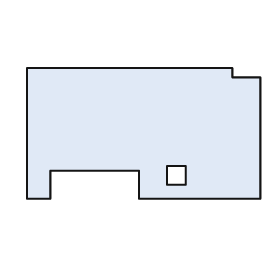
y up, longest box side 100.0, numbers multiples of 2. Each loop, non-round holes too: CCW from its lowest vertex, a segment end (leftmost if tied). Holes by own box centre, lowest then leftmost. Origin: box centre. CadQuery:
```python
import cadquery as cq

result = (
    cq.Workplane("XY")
    .moveTo(-50.0, -28.0)
    .lineTo(-40.0, -28.0)
    .lineTo(-40.0, -16.0)
    .lineTo(-2.0, -16.0)
    .lineTo(-2.0, -28.0)
    .lineTo(50.0, -28.0)
    .lineTo(50.0, 24.0)
    .lineTo(38.0, 24.0)
    .lineTo(38.0, 28.0)
    .lineTo(-50.0, 28.0)
    .close()
    .moveTo(10.0, -22.0)
    .lineTo(18.0, -22.0)
    .lineTo(18.0, -14.0)
    .lineTo(10.0, -14.0)
    .close()
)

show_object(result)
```